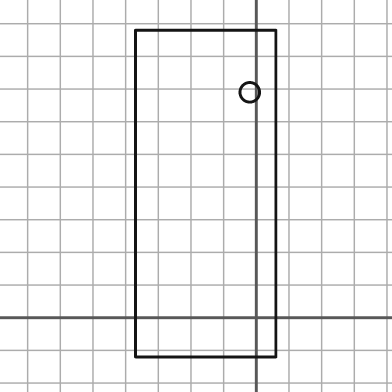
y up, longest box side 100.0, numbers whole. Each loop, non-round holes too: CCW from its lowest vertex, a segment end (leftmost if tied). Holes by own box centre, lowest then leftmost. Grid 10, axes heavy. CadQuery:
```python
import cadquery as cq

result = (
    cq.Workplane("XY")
    .moveTo(-37.0, -12.0)
    .lineTo(6.0, -12.0)
    .lineTo(6.0, 88.0)
    .lineTo(-37.0, 88.0)
    .close()
    .moveTo(-2.0, 69.0)
    .circle(3.0)
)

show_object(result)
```